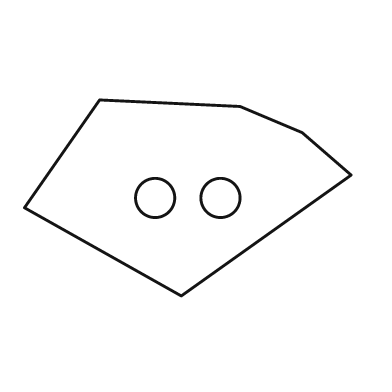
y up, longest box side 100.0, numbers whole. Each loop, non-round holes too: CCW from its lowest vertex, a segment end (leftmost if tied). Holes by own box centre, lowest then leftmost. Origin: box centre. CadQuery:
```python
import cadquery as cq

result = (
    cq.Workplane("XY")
    .moveTo(-2.0, -30.0)
    .lineTo(50.0, 7.0)
    .lineTo(35.0, 20.0)
    .lineTo(16.0, 28.0)
    .lineTo(-27.0, 30.0)
    .lineTo(-50.0, -3.0)
    .close()
    .moveTo(-10.0, 0.0)
    .circle(6.0)
    .moveTo(10.0, 0.0)
    .circle(6.0)
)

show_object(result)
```